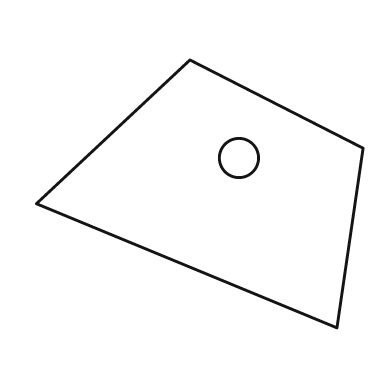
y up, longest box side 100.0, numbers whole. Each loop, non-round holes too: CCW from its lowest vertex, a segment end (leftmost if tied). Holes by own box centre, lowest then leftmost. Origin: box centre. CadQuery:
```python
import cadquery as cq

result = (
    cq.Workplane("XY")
    .moveTo(42.0, -41.0)
    .lineTo(50.0, 14.0)
    .lineTo(-3.0, 41.0)
    .lineTo(-50.0, -3.0)
    .close()
    .moveTo(12.0, 11.0)
    .circle(6.0)
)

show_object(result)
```